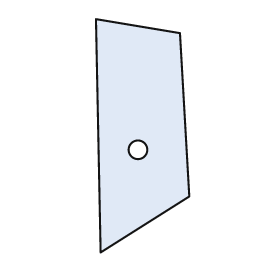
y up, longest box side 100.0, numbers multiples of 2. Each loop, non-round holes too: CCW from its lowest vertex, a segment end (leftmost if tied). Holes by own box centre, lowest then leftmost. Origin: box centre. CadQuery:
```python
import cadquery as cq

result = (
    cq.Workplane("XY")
    .moveTo(-18.0, -50.0)
    .lineTo(20.0, -26.0)
    .lineTo(16.0, 44.0)
    .lineTo(-20.0, 50.0)
    .close()
    .moveTo(-2.0, -6.0)
    .circle(4.0)
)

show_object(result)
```